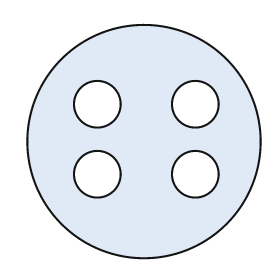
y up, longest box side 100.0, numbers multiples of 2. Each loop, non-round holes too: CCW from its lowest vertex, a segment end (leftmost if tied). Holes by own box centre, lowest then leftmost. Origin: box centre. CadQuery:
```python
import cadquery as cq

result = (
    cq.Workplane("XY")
    .moveTo(0.0, 0.0)
    .circle(50.0)
    .moveTo(-20.0, -14.0)
    .circle(10.0)
    .moveTo(22.0, -14.0)
    .circle(10.0)
    .moveTo(-20.0, 16.0)
    .circle(10.0)
    .moveTo(22.0, 16.0)
    .circle(10.0)
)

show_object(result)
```